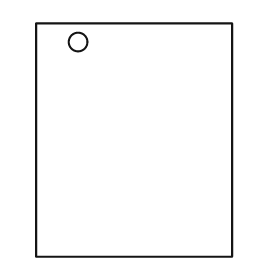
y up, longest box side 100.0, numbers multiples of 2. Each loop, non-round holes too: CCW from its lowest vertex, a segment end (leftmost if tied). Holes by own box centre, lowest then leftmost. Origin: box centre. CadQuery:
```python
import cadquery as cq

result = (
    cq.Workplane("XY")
    .moveTo(-42.0, -50.0)
    .lineTo(42.0, -50.0)
    .lineTo(42.0, 50.0)
    .lineTo(-42.0, 50.0)
    .close()
    .moveTo(-24.0, 42.0)
    .circle(4.0)
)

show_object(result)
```